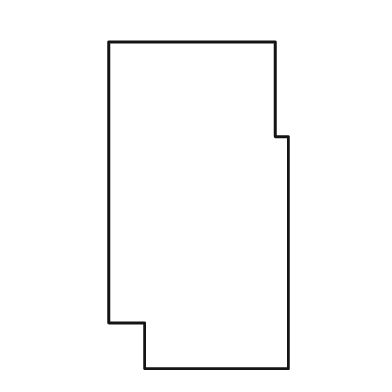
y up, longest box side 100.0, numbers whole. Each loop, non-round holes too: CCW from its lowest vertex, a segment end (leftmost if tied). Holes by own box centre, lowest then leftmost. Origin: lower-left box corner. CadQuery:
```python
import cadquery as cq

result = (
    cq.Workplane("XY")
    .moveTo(11.0, 0.0)
    .lineTo(55.0, 0.0)
    .lineTo(55.0, 71.0)
    .lineTo(51.0, 71.0)
    .lineTo(51.0, 100.0)
    .lineTo(0.0, 100.0)
    .lineTo(0.0, 14.0)
    .lineTo(11.0, 14.0)
    .close()
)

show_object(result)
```